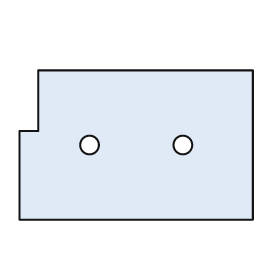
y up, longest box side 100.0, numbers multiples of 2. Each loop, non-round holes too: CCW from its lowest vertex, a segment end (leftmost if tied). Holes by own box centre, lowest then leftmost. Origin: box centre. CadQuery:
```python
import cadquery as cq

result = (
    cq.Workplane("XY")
    .moveTo(-50.0, -32.0)
    .lineTo(50.0, -32.0)
    .lineTo(50.0, 32.0)
    .lineTo(-42.0, 32.0)
    .lineTo(-42.0, 6.0)
    .lineTo(-50.0, 6.0)
    .close()
    .moveTo(-20.0, 0.0)
    .circle(4.0)
    .moveTo(20.0, 0.0)
    .circle(4.0)
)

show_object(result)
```